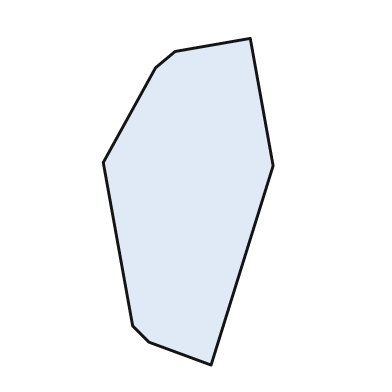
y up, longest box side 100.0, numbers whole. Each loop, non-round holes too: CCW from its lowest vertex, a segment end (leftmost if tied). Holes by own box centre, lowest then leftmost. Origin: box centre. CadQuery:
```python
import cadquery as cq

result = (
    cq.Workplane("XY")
    .moveTo(7.0, -50.0)
    .lineTo(26.0, 11.0)
    .lineTo(19.0, 50.0)
    .lineTo(-4.0, 46.0)
    .lineTo(-10.0, 41.0)
    .lineTo(-26.0, 12.0)
    .lineTo(-17.0, -38.0)
    .lineTo(-12.0, -43.0)
    .close()
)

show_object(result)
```